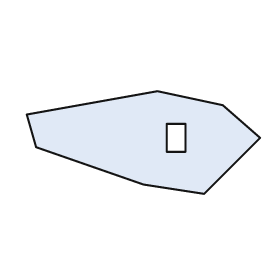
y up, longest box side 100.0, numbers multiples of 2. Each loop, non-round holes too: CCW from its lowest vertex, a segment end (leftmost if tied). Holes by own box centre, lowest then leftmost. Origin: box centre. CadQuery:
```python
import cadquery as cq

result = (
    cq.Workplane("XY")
    .moveTo(26.0, -22.0)
    .lineTo(50.0, 2.0)
    .lineTo(34.0, 16.0)
    .lineTo(6.0, 22.0)
    .lineTo(-50.0, 12.0)
    .lineTo(-46.0, -2.0)
    .lineTo(0.0, -18.0)
    .close()
    .moveTo(10.0, -4.0)
    .lineTo(18.0, -4.0)
    .lineTo(18.0, 8.0)
    .lineTo(10.0, 8.0)
    .close()
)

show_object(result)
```